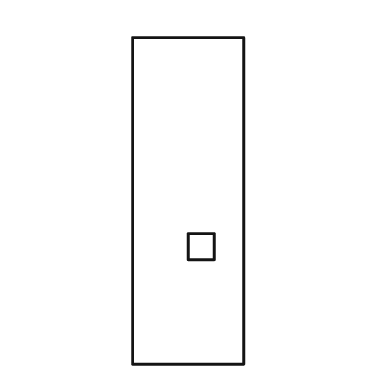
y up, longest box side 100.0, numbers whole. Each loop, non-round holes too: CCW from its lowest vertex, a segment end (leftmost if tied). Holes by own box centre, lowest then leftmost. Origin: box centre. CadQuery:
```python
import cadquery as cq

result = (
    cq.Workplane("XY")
    .moveTo(-17.0, -50.0)
    .lineTo(17.0, -50.0)
    .lineTo(17.0, 50.0)
    .lineTo(-17.0, 50.0)
    .close()
    .moveTo(0.0, -18.0)
    .lineTo(8.0, -18.0)
    .lineTo(8.0, -10.0)
    .lineTo(0.0, -10.0)
    .close()
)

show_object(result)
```